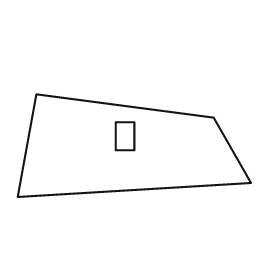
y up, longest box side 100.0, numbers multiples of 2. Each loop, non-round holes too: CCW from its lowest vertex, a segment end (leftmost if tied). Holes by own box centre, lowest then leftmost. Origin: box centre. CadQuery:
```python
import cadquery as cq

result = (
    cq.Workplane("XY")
    .moveTo(-50.0, -22.0)
    .lineTo(50.0, -16.0)
    .lineTo(34.0, 12.0)
    .lineTo(-42.0, 22.0)
    .close()
    .moveTo(-8.0, -2.0)
    .lineTo(0.0, -2.0)
    .lineTo(0.0, 10.0)
    .lineTo(-8.0, 10.0)
    .close()
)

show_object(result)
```